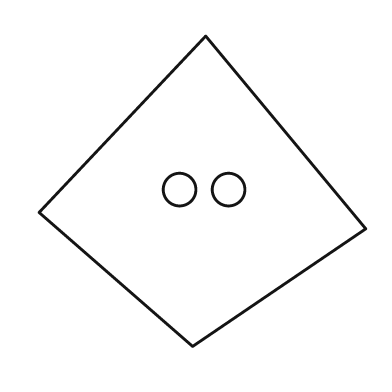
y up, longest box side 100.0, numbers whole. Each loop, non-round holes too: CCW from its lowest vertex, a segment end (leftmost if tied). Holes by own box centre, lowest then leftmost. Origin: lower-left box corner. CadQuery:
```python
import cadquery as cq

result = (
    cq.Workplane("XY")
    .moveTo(47.0, 0.0)
    .lineTo(100.0, 36.0)
    .lineTo(51.0, 95.0)
    .lineTo(0.0, 41.0)
    .close()
    .moveTo(43.0, 48.0)
    .circle(5.0)
    .moveTo(58.0, 48.0)
    .circle(5.0)
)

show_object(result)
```